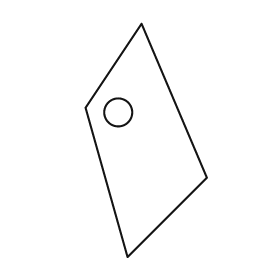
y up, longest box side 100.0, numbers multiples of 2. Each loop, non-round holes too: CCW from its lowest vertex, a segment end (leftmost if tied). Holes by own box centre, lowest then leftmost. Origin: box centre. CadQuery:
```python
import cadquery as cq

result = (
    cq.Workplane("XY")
    .moveTo(-8.0, -50.0)
    .lineTo(26.0, -16.0)
    .lineTo(-2.0, 50.0)
    .lineTo(-26.0, 14.0)
    .close()
    .moveTo(-12.0, 12.0)
    .circle(6.0)
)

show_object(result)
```